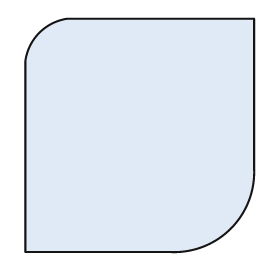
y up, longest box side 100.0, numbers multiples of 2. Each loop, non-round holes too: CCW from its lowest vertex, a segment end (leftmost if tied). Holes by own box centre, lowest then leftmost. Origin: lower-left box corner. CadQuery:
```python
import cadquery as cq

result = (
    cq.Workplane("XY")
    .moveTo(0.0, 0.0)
    .lineTo(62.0, 0.0)
    .threePointArc((88.0, 10.0), (98.0, 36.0))
    .lineTo(98.0, 100.0)
    .lineTo(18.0, 100.0)
    .threePointArc((6.0, 94.0), (0.0, 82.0))
    .close()
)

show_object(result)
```